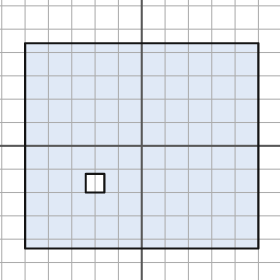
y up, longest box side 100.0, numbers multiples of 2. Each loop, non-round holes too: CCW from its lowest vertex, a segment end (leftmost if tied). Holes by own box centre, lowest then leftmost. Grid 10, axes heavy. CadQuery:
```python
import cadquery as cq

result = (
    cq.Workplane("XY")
    .moveTo(-50.0, -44.0)
    .lineTo(50.0, -44.0)
    .lineTo(50.0, 44.0)
    .lineTo(-50.0, 44.0)
    .close()
    .moveTo(-24.0, -20.0)
    .lineTo(-16.0, -20.0)
    .lineTo(-16.0, -12.0)
    .lineTo(-24.0, -12.0)
    .close()
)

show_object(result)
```